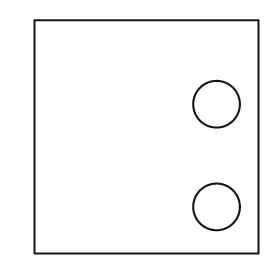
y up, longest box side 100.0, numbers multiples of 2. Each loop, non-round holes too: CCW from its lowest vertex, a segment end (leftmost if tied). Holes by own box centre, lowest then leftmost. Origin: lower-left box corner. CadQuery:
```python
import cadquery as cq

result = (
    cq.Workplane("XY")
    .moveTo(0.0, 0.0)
    .lineTo(96.0, 0.0)
    .lineTo(96.0, 100.0)
    .lineTo(0.0, 100.0)
    .close()
    .moveTo(78.0, 20.0)
    .circle(10.0)
    .moveTo(78.0, 64.0)
    .circle(10.0)
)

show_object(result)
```